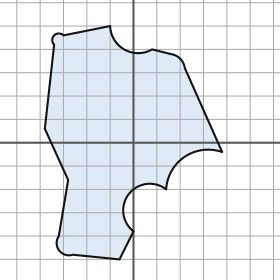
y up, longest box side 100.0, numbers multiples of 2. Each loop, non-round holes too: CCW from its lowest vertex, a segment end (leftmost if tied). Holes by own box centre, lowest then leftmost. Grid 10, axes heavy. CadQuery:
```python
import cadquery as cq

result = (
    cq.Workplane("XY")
    .moveTo(-6.0, -50.0)
    .lineTo(0.0, -38.0)
    .threePointArc((-2.0, -22.0), (14.0, -20.0))
    .threePointArc((22.0, -6.0), (38.0, -4.0))
    .lineTo(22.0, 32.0)
    .threePointArc((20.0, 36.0), (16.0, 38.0))
    .lineTo(8.0, 40.0)
    .threePointArc((-4.0, 40.0), (-10.0, 50.0))
    .lineTo(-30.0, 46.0)
    .threePointArc((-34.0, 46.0), (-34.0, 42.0))
    .lineTo(-38.0, 6.0)
    .lineTo(-28.0, -16.0)
    .lineTo(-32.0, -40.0)
    .threePointArc((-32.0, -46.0), (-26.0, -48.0))
    .close()
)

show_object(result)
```